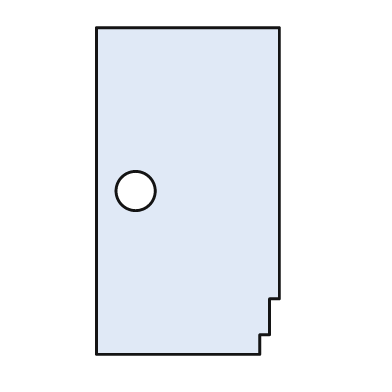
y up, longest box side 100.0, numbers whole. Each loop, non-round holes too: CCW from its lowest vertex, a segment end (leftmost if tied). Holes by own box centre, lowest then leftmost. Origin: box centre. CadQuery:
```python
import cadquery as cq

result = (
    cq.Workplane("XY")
    .moveTo(-28.0, -50.0)
    .lineTo(22.0, -50.0)
    .lineTo(22.0, -44.0)
    .lineTo(25.0, -44.0)
    .lineTo(25.0, -33.0)
    .lineTo(28.0, -33.0)
    .lineTo(28.0, 50.0)
    .lineTo(-28.0, 50.0)
    .close()
    .moveTo(-16.0, 0.0)
    .circle(6.0)
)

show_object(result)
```